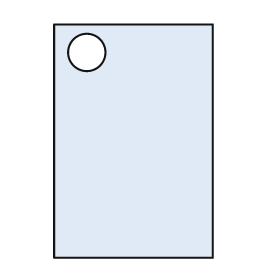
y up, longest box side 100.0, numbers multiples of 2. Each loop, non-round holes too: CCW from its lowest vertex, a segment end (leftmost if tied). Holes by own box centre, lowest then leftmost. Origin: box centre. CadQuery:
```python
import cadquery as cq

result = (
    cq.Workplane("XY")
    .moveTo(-34.0, -50.0)
    .lineTo(34.0, -50.0)
    .lineTo(34.0, 50.0)
    .lineTo(-34.0, 50.0)
    .close()
    .moveTo(-20.0, 38.0)
    .circle(8.0)
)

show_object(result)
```